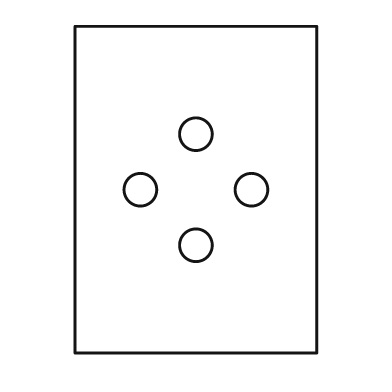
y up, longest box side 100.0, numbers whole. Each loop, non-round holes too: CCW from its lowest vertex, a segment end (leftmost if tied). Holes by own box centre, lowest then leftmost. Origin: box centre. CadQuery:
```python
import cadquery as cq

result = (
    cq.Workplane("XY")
    .moveTo(-37.0, -50.0)
    .lineTo(37.0, -50.0)
    .lineTo(37.0, 50.0)
    .lineTo(-37.0, 50.0)
    .close()
    .moveTo(0.0, -17.0)
    .circle(5.0)
    .moveTo(-17.0, 0.0)
    .circle(5.0)
    .moveTo(17.0, 0.0)
    .circle(5.0)
    .moveTo(0.0, 17.0)
    .circle(5.0)
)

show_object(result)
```